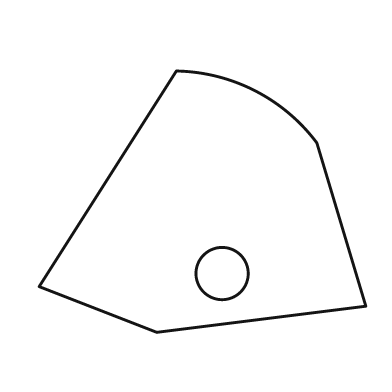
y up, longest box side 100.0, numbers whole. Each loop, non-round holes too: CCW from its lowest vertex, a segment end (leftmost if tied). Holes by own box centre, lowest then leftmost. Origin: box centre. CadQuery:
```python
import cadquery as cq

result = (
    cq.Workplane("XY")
    .moveTo(-14.0, -40.0)
    .lineTo(50.0, -32.0)
    .lineTo(35.0, 18.0)
    .threePointArc((16.0, 34.0), (-8.0, 40.0))
    .lineTo(-50.0, -26.0)
    .close()
    .moveTo(6.0, -22.0)
    .circle(8.0)
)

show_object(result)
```